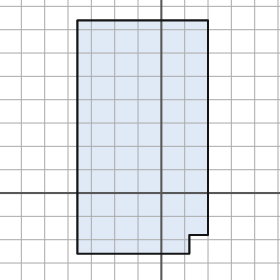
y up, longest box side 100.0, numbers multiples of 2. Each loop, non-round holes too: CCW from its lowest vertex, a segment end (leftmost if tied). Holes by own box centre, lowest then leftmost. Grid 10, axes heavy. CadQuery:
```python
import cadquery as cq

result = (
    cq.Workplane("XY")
    .moveTo(-36.0, -26.0)
    .lineTo(12.0, -26.0)
    .lineTo(12.0, -18.0)
    .lineTo(20.0, -18.0)
    .lineTo(20.0, 74.0)
    .lineTo(-36.0, 74.0)
    .close()
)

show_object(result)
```